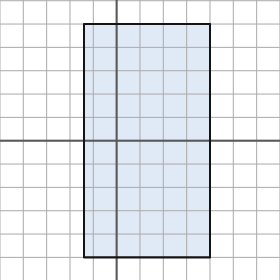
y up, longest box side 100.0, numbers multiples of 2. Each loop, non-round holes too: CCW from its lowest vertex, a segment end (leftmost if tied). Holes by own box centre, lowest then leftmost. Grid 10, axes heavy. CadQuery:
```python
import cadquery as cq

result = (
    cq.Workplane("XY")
    .moveTo(-14.0, -50.0)
    .lineTo(40.0, -50.0)
    .lineTo(40.0, 50.0)
    .lineTo(-14.0, 50.0)
    .close()
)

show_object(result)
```